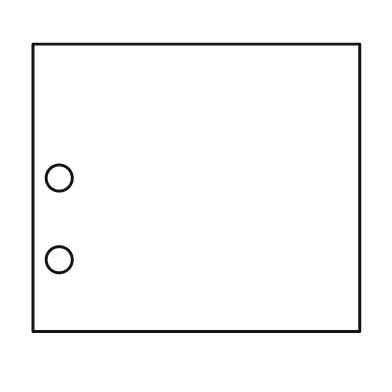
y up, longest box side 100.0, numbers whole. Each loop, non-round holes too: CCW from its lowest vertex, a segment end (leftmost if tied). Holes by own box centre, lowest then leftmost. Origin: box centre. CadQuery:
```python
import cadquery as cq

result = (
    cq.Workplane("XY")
    .moveTo(-50.0, -44.0)
    .lineTo(50.0, -44.0)
    .lineTo(50.0, 44.0)
    .lineTo(-50.0, 44.0)
    .close()
    .moveTo(-42.0, -22.0)
    .circle(4.0)
    .moveTo(-42.0, 3.0)
    .circle(4.0)
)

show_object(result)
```